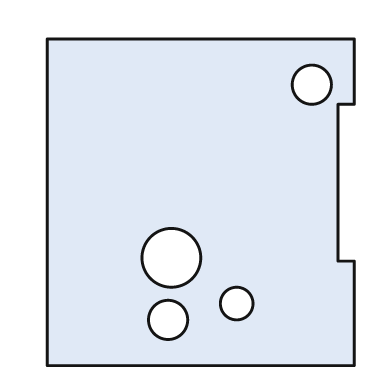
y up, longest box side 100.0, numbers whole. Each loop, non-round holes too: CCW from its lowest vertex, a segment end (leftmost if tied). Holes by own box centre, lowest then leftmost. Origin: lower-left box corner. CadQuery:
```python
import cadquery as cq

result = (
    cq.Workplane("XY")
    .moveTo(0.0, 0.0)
    .lineTo(94.0, 0.0)
    .lineTo(94.0, 32.0)
    .lineTo(89.0, 32.0)
    .lineTo(89.0, 80.0)
    .lineTo(94.0, 80.0)
    .lineTo(94.0, 100.0)
    .lineTo(0.0, 100.0)
    .close()
    .moveTo(37.0, 14.0)
    .circle(6.0)
    .moveTo(58.0, 19.0)
    .circle(5.0)
    .moveTo(38.0, 33.0)
    .circle(9.0)
    .moveTo(81.0, 86.0)
    .circle(6.0)
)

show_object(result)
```